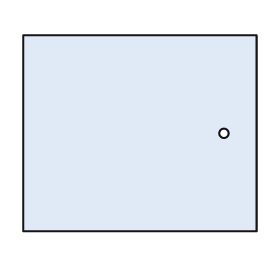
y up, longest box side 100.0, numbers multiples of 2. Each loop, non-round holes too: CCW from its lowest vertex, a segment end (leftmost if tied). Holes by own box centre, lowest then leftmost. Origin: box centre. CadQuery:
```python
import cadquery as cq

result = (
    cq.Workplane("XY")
    .moveTo(-50.0, -42.0)
    .lineTo(50.0, -42.0)
    .lineTo(50.0, 42.0)
    .lineTo(-50.0, 42.0)
    .close()
    .moveTo(36.0, 0.0)
    .circle(2.0)
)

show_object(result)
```